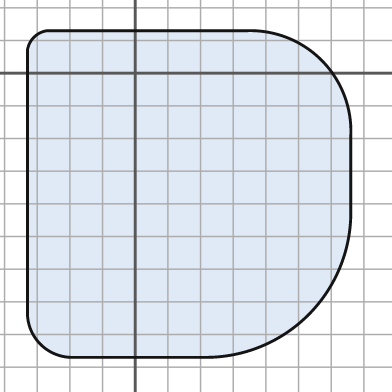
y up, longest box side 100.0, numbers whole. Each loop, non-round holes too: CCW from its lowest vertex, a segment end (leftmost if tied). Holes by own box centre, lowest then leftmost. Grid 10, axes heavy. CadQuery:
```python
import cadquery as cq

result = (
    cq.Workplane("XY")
    .moveTo(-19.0, -87.0)
    .lineTo(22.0, -87.0)
    .threePointArc((53.0, -74.0), (66.0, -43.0))
    .lineTo(66.0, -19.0)
    .threePointArc((57.0, 4.0), (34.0, 13.0))
    .lineTo(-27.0, 13.0)
    .threePointArc((-31.0, 11.0), (-33.0, 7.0))
    .lineTo(-33.0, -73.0)
    .threePointArc((-29.0, -83.0), (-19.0, -87.0))
    .close()
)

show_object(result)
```